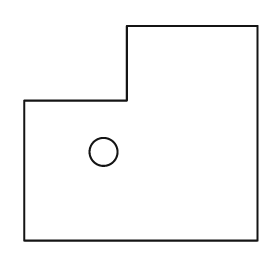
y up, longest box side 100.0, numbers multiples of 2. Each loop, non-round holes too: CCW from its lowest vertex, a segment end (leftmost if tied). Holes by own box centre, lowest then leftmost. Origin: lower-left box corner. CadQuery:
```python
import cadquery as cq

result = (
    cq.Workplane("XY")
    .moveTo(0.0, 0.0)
    .lineTo(100.0, 0.0)
    .lineTo(100.0, 92.0)
    .lineTo(44.0, 92.0)
    .lineTo(44.0, 60.0)
    .lineTo(0.0, 60.0)
    .close()
    .moveTo(34.0, 38.0)
    .circle(6.0)
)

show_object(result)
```